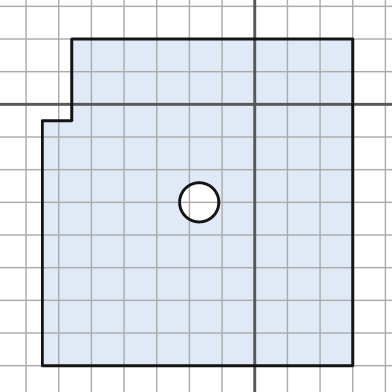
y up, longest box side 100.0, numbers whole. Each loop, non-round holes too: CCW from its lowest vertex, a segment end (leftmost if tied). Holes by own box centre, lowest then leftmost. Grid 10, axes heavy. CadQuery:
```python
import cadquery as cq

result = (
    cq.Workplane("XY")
    .moveTo(-65.0, -80.0)
    .lineTo(30.0, -80.0)
    .lineTo(30.0, 20.0)
    .lineTo(-56.0, 20.0)
    .lineTo(-56.0, -5.0)
    .lineTo(-65.0, -5.0)
    .close()
    .moveTo(-17.0, -30.0)
    .circle(6.0)
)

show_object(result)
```